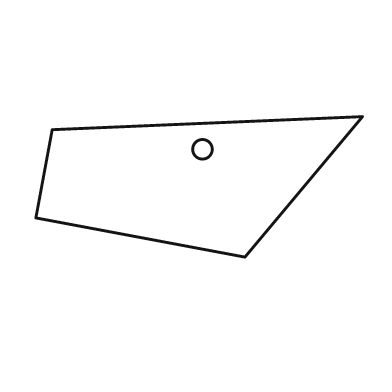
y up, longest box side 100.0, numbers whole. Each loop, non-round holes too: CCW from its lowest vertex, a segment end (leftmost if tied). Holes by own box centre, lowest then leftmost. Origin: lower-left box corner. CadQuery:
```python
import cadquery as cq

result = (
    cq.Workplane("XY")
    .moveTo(64.0, 0.0)
    .lineTo(100.0, 43.0)
    .lineTo(5.0, 39.0)
    .lineTo(0.0, 12.0)
    .close()
    .moveTo(51.0, 33.0)
    .circle(3.0)
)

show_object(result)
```